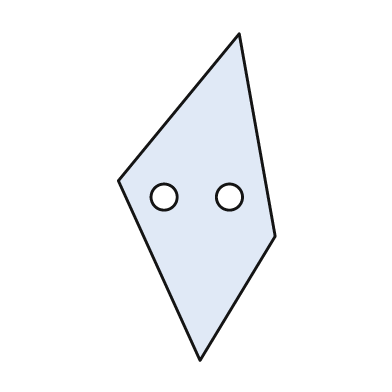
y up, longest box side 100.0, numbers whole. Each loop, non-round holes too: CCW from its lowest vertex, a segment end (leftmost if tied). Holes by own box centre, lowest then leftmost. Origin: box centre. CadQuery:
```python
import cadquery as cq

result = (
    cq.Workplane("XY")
    .moveTo(1.0, -50.0)
    .lineTo(24.0, -12.0)
    .lineTo(13.0, 50.0)
    .lineTo(-24.0, 5.0)
    .close()
    .moveTo(-10.0, 0.0)
    .circle(4.0)
    .moveTo(10.0, 0.0)
    .circle(4.0)
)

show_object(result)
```